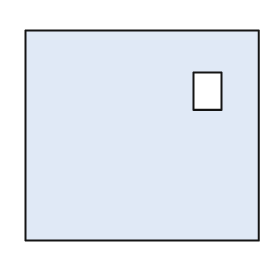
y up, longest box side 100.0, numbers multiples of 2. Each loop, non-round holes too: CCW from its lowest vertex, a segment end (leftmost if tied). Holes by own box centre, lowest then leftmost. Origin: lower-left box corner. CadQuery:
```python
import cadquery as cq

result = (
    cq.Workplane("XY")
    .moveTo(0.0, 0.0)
    .lineTo(100.0, 0.0)
    .lineTo(100.0, 90.0)
    .lineTo(0.0, 90.0)
    .close()
    .moveTo(72.0, 56.0)
    .lineTo(84.0, 56.0)
    .lineTo(84.0, 72.0)
    .lineTo(72.0, 72.0)
    .close()
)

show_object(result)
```